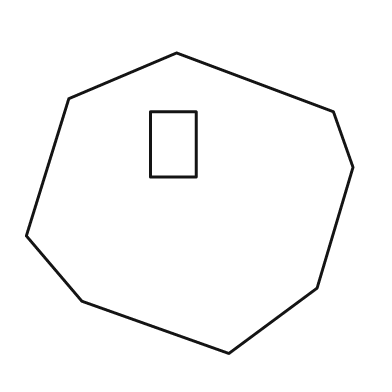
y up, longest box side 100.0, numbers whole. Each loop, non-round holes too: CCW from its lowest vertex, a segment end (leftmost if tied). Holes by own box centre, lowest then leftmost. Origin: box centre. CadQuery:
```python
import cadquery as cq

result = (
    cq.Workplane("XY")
    .moveTo(12.0, -46.0)
    .lineTo(39.0, -26.0)
    .lineTo(50.0, 11.0)
    .lineTo(44.0, 28.0)
    .lineTo(-4.0, 46.0)
    .lineTo(-37.0, 32.0)
    .lineTo(-50.0, -10.0)
    .lineTo(-33.0, -30.0)
    .close()
    .moveTo(-12.0, 8.0)
    .lineTo(2.0, 8.0)
    .lineTo(2.0, 28.0)
    .lineTo(-12.0, 28.0)
    .close()
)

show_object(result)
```